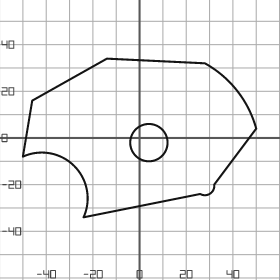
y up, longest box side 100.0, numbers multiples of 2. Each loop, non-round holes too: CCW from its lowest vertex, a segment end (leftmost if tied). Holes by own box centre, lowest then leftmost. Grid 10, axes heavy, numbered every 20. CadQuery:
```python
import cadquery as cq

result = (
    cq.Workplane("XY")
    .moveTo(-24.0, -34.0)
    .lineTo(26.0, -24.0)
    .threePointArc((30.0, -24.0), (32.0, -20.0))
    .lineTo(50.0, 4.0)
    .threePointArc((42.0, 20.0), (28.0, 32.0))
    .lineTo(-14.0, 34.0)
    .lineTo(-46.0, 16.0)
    .lineTo(-50.0, -8.0)
    .threePointArc((-28.0, -12.0), (-24.0, -34.0))
    .close()
    .moveTo(4.0, -2.0)
    .circle(8.0)
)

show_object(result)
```